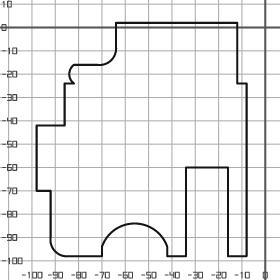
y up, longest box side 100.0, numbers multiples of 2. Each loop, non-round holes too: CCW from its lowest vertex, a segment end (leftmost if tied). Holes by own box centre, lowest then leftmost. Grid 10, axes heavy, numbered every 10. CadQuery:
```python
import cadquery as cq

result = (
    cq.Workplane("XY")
    .moveTo(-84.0, -98.0)
    .lineTo(-70.0, -98.0)
    .lineTo(-70.0, -94.0)
    .threePointArc((-56.0, -84.0), (-42.0, -94.0))
    .lineTo(-42.0, -98.0)
    .lineTo(-34.0, -98.0)
    .lineTo(-34.0, -60.0)
    .lineTo(-16.0, -60.0)
    .lineTo(-16.0, -98.0)
    .lineTo(-8.0, -98.0)
    .lineTo(-8.0, -24.0)
    .lineTo(-12.0, -24.0)
    .lineTo(-12.0, 2.0)
    .lineTo(-64.0, 2.0)
    .lineTo(-64.0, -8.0)
    .threePointArc((-66.0, -14.0), (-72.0, -16.0))
    .lineTo(-82.0, -16.0)
    .threePointArc((-84.0, -20.0), (-82.0, -24.0))
    .lineTo(-86.0, -24.0)
    .lineTo(-86.0, -42.0)
    .lineTo(-98.0, -42.0)
    .lineTo(-98.0, -70.0)
    .lineTo(-92.0, -70.0)
    .lineTo(-92.0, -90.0)
    .threePointArc((-90.0, -96.0), (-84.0, -98.0))
    .close()
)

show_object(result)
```